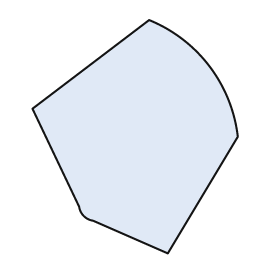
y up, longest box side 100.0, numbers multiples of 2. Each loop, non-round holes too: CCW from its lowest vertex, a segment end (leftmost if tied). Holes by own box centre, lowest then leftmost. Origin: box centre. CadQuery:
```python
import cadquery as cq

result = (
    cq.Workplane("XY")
    .moveTo(14.0, -50.0)
    .lineTo(44.0, 0.0)
    .threePointArc((32.0, 30.0), (6.0, 50.0))
    .lineTo(-44.0, 12.0)
    .lineTo(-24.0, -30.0)
    .threePointArc((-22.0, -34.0), (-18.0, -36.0))
    .close()
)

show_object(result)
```